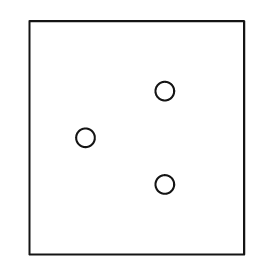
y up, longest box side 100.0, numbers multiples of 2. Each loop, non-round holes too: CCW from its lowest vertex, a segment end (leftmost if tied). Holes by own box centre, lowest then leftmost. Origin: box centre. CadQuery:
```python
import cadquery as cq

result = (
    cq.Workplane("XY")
    .moveTo(-46.0, -50.0)
    .lineTo(46.0, -50.0)
    .lineTo(46.0, 50.0)
    .lineTo(-46.0, 50.0)
    .close()
    .moveTo(12.0, -20.0)
    .circle(4.0)
    .moveTo(-22.0, 0.0)
    .circle(4.0)
    .moveTo(12.0, 20.0)
    .circle(4.0)
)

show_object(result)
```